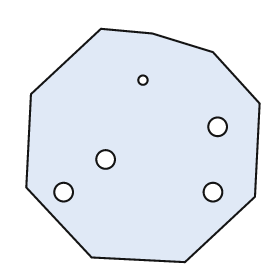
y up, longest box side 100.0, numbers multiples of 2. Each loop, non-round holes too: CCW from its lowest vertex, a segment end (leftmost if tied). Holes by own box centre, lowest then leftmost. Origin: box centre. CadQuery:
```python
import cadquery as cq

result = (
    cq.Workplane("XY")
    .moveTo(18.0, -50.0)
    .lineTo(48.0, -22.0)
    .lineTo(50.0, 18.0)
    .lineTo(30.0, 40.0)
    .lineTo(4.0, 48.0)
    .lineTo(-18.0, 50.0)
    .lineTo(-48.0, 22.0)
    .lineTo(-50.0, -18.0)
    .lineTo(-22.0, -48.0)
    .close()
    .moveTo(-34.0, -20.0)
    .circle(4.0)
    .moveTo(30.0, -20.0)
    .circle(4.0)
    .moveTo(-16.0, -6.0)
    .circle(4.0)
    .moveTo(32.0, 8.0)
    .circle(4.0)
    .moveTo(0.0, 28.0)
    .circle(2.0)
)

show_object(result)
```